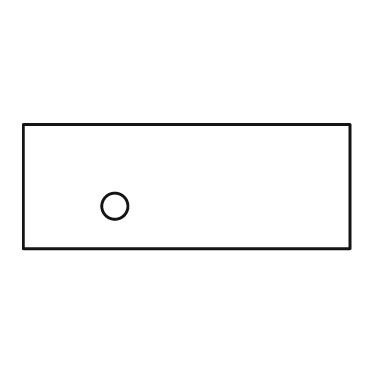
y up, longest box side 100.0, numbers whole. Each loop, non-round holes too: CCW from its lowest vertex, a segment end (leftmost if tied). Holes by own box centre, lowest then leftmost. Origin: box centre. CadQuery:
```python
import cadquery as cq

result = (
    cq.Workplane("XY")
    .moveTo(-50.0, -19.0)
    .lineTo(50.0, -19.0)
    .lineTo(50.0, 19.0)
    .lineTo(-50.0, 19.0)
    .close()
    .moveTo(-22.0, -6.0)
    .circle(4.0)
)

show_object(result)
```